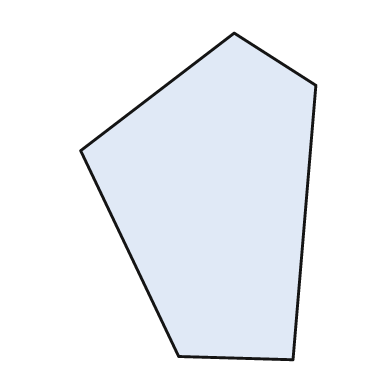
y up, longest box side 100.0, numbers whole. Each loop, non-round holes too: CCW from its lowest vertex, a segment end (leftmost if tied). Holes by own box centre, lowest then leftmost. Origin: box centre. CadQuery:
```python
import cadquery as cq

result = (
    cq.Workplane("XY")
    .moveTo(29.0, -50.0)
    .lineTo(36.0, 34.0)
    .lineTo(11.0, 50.0)
    .lineTo(-36.0, 14.0)
    .lineTo(-6.0, -49.0)
    .close()
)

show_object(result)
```